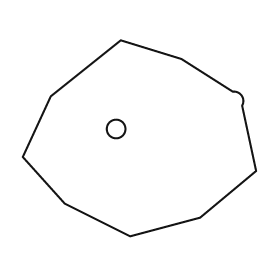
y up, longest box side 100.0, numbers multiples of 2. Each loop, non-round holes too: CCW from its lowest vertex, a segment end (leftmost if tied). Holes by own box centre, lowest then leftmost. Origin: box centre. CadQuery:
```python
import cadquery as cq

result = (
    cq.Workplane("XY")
    .moveTo(-4.0, -42.0)
    .lineTo(26.0, -34.0)
    .lineTo(50.0, -14.0)
    .lineTo(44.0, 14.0)
    .threePointArc((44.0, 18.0), (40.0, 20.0))
    .lineTo(18.0, 34.0)
    .lineTo(-8.0, 42.0)
    .lineTo(-38.0, 18.0)
    .lineTo(-50.0, -8.0)
    .lineTo(-32.0, -28.0)
    .close()
    .moveTo(-10.0, 4.0)
    .circle(4.0)
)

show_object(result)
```